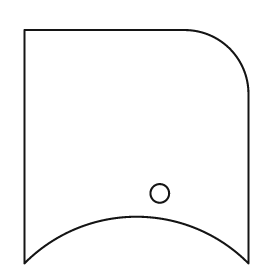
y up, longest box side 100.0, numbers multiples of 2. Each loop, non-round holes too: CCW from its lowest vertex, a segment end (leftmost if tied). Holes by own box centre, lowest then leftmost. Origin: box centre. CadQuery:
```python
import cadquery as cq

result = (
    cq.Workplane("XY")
    .moveTo(-48.0, -50.0)
    .threePointArc((0.0, -30.0), (48.0, -50.0))
    .lineTo(48.0, 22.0)
    .threePointArc((40.0, 42.0), (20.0, 50.0))
    .lineTo(-48.0, 50.0)
    .close()
    .moveTo(10.0, -20.0)
    .circle(4.0)
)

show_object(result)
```